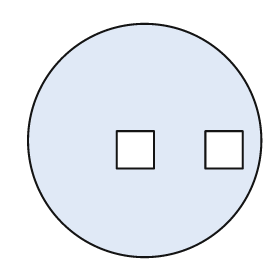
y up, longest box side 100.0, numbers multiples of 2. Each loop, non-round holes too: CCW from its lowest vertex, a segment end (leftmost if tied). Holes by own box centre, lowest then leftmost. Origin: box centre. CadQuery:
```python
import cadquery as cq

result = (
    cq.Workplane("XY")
    .moveTo(0.0, 0.0)
    .circle(50.0)
    .moveTo(-12.0, -12.0)
    .lineTo(4.0, -12.0)
    .lineTo(4.0, 4.0)
    .lineTo(-12.0, 4.0)
    .close()
    .moveTo(26.0, -12.0)
    .lineTo(42.0, -12.0)
    .lineTo(42.0, 4.0)
    .lineTo(26.0, 4.0)
    .close()
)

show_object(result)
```